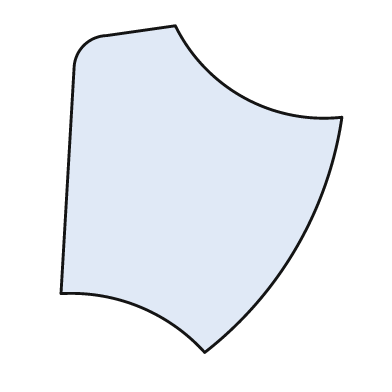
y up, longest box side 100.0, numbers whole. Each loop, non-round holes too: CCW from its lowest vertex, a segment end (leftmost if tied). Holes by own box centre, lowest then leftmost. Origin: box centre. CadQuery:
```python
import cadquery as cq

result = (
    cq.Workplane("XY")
    .moveTo(1.0, -50.0)
    .threePointArc((29.0, -18.0), (43.0, 22.0))
    .threePointArc((13.0, 28.0), (-8.0, 50.0))
    .lineTo(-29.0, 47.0)
    .threePointArc((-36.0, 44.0), (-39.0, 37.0))
    .lineTo(-43.0, -32.0)
    .threePointArc((-19.0, -36.0), (1.0, -50.0))
    .close()
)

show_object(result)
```